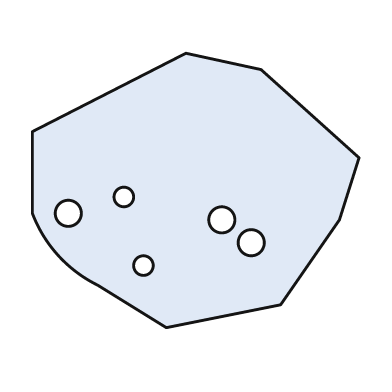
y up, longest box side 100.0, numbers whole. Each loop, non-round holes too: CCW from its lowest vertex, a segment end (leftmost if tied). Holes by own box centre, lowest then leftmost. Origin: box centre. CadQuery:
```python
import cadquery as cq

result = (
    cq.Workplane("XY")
    .moveTo(-9.0, -42.0)
    .lineTo(26.0, -35.0)
    .lineTo(44.0, -9.0)
    .lineTo(50.0, 10.0)
    .lineTo(20.0, 37.0)
    .lineTo(-3.0, 42.0)
    .lineTo(-50.0, 18.0)
    .lineTo(-50.0, -7.0)
    .threePointArc((-42.0, -20.0), (-30.0, -29.0))
    .close()
    .moveTo(-16.0, -23.0)
    .circle(3.0)
    .moveTo(17.0, -16.0)
    .circle(4.0)
    .moveTo(8.0, -9.0)
    .circle(4.0)
    .moveTo(-39.0, -7.0)
    .circle(4.0)
    .moveTo(-22.0, -2.0)
    .circle(3.0)
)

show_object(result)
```